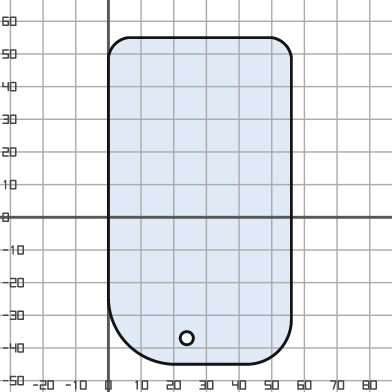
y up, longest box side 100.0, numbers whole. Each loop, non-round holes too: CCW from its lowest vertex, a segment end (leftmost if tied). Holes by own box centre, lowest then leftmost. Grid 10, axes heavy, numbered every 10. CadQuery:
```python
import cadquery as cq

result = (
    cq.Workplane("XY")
    .moveTo(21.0, -45.0)
    .lineTo(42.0, -45.0)
    .threePointArc((52.0, -41.0), (56.0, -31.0))
    .lineTo(56.0, 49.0)
    .threePointArc((54.0, 53.0), (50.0, 55.0))
    .lineTo(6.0, 55.0)
    .threePointArc((2.0, 53.0), (0.0, 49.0))
    .lineTo(0.0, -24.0)
    .threePointArc((6.0, -39.0), (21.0, -45.0))
    .close()
    .moveTo(24.0, -37.0)
    .circle(2.0)
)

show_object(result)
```